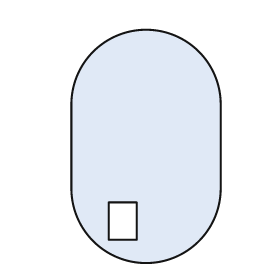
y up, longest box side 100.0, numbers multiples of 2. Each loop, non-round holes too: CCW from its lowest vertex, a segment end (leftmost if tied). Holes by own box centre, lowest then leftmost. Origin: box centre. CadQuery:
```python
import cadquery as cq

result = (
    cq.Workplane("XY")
    .moveTo(-32.0, -18.0)
    .threePointArc((0.0, -50.0), (32.0, -18.0))
    .lineTo(32.0, 18.0)
    .threePointArc((0.0, 50.0), (-32.0, 18.0))
    .close()
    .moveTo(-16.0, -40.0)
    .lineTo(-4.0, -40.0)
    .lineTo(-4.0, -24.0)
    .lineTo(-16.0, -24.0)
    .close()
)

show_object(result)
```